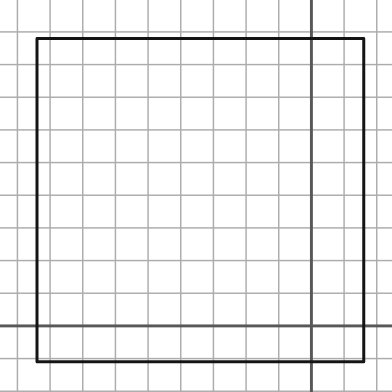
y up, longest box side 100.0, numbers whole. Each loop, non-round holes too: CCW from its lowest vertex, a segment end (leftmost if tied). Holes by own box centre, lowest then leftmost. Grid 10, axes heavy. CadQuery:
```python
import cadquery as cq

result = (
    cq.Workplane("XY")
    .moveTo(-84.0, -11.0)
    .lineTo(16.0, -11.0)
    .lineTo(16.0, 88.0)
    .lineTo(-84.0, 88.0)
    .close()
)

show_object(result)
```